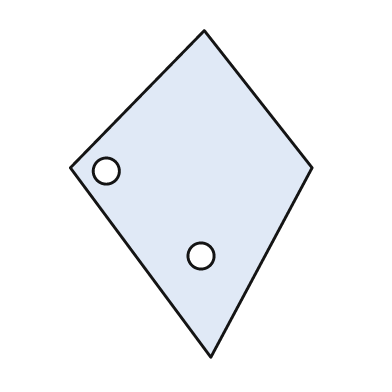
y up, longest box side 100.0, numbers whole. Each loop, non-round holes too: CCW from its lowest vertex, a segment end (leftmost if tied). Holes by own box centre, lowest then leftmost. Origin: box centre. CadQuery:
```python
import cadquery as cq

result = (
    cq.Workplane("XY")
    .moveTo(6.0, -50.0)
    .lineTo(37.0, 8.0)
    .lineTo(4.0, 50.0)
    .lineTo(-37.0, 8.0)
    .close()
    .moveTo(3.0, -19.0)
    .circle(4.0)
    .moveTo(-26.0, 7.0)
    .circle(4.0)
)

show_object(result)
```